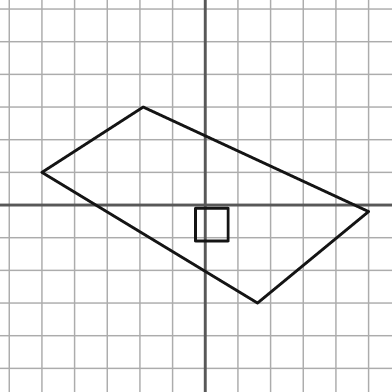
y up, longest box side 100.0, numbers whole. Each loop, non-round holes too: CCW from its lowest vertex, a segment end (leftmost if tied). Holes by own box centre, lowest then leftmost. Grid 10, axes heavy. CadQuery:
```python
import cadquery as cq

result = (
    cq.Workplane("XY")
    .moveTo(16.0, -30.0)
    .lineTo(50.0, -2.0)
    .lineTo(-19.0, 30.0)
    .lineTo(-50.0, 10.0)
    .close()
    .moveTo(-3.0, -11.0)
    .lineTo(7.0, -11.0)
    .lineTo(7.0, -1.0)
    .lineTo(-3.0, -1.0)
    .close()
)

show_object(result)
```